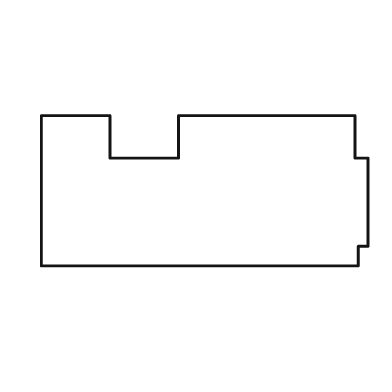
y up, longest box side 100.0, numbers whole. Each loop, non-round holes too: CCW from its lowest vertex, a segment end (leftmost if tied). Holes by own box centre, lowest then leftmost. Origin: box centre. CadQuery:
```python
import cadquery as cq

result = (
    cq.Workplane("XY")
    .moveTo(-50.0, -23.0)
    .lineTo(47.0, -23.0)
    .lineTo(47.0, -17.0)
    .lineTo(50.0, -17.0)
    .lineTo(50.0, 10.0)
    .lineTo(46.0, 10.0)
    .lineTo(46.0, 23.0)
    .lineTo(-8.0, 23.0)
    .lineTo(-8.0, 10.0)
    .lineTo(-29.0, 10.0)
    .lineTo(-29.0, 23.0)
    .lineTo(-50.0, 23.0)
    .close()
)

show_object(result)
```